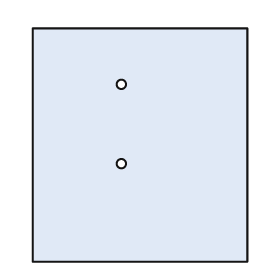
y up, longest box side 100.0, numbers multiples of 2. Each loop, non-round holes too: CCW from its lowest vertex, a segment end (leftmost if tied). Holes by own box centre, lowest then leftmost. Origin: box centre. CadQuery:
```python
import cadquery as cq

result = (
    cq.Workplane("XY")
    .moveTo(-46.0, -50.0)
    .lineTo(46.0, -50.0)
    .lineTo(46.0, 50.0)
    .lineTo(-46.0, 50.0)
    .close()
    .moveTo(-8.0, -8.0)
    .circle(2.0)
    .moveTo(-8.0, 26.0)
    .circle(2.0)
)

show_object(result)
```